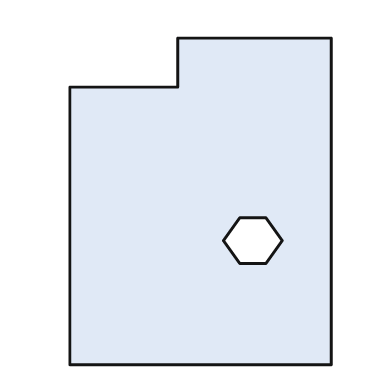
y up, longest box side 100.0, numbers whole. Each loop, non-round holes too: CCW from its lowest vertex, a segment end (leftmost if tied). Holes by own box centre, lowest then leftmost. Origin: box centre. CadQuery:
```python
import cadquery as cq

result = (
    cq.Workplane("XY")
    .moveTo(-40.0, -50.0)
    .lineTo(40.0, -50.0)
    .lineTo(40.0, 50.0)
    .lineTo(-7.0, 50.0)
    .lineTo(-7.0, 35.0)
    .lineTo(-40.0, 35.0)
    .close()
    .moveTo(12.0, -19.0)
    .lineTo(20.0, -19.0)
    .lineTo(25.0, -12.0)
    .lineTo(20.0, -5.0)
    .lineTo(12.0, -5.0)
    .lineTo(7.0, -12.0)
    .close()
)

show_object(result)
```